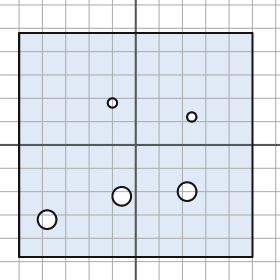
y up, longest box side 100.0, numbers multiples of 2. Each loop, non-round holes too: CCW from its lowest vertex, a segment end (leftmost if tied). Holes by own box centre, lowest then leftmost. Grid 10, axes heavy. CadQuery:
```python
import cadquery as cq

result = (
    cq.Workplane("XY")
    .moveTo(-50.0, -48.0)
    .lineTo(50.0, -48.0)
    .lineTo(50.0, 48.0)
    .lineTo(-50.0, 48.0)
    .close()
    .moveTo(-38.0, -32.0)
    .circle(4.0)
    .moveTo(-6.0, -22.0)
    .circle(4.0)
    .moveTo(22.0, -20.0)
    .circle(4.0)
    .moveTo(24.0, 12.0)
    .circle(2.0)
    .moveTo(-10.0, 18.0)
    .circle(2.0)
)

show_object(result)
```